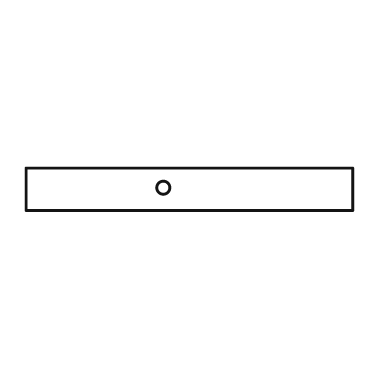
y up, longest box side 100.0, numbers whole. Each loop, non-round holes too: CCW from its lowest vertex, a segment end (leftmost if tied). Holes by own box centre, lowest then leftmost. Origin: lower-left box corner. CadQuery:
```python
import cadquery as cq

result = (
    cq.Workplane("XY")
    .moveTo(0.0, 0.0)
    .lineTo(100.0, 0.0)
    .lineTo(100.0, 13.0)
    .lineTo(0.0, 13.0)
    .close()
    .moveTo(42.0, 7.0)
    .circle(2.0)
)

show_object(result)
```